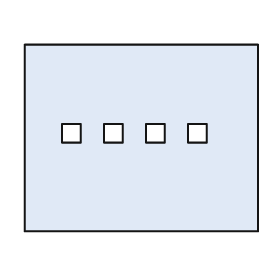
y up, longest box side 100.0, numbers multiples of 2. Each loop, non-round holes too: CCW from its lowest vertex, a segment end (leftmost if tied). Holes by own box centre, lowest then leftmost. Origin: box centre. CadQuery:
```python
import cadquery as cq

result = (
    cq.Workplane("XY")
    .moveTo(-50.0, -40.0)
    .lineTo(50.0, -40.0)
    .lineTo(50.0, 40.0)
    .lineTo(-50.0, 40.0)
    .close()
    .moveTo(-34.0, -2.0)
    .lineTo(-26.0, -2.0)
    .lineTo(-26.0, 6.0)
    .lineTo(-34.0, 6.0)
    .close()
    .moveTo(-16.0, -2.0)
    .lineTo(-8.0, -2.0)
    .lineTo(-8.0, 6.0)
    .lineTo(-16.0, 6.0)
    .close()
    .moveTo(2.0, -2.0)
    .lineTo(10.0, -2.0)
    .lineTo(10.0, 6.0)
    .lineTo(2.0, 6.0)
    .close()
    .moveTo(20.0, -2.0)
    .lineTo(28.0, -2.0)
    .lineTo(28.0, 6.0)
    .lineTo(20.0, 6.0)
    .close()
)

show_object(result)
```